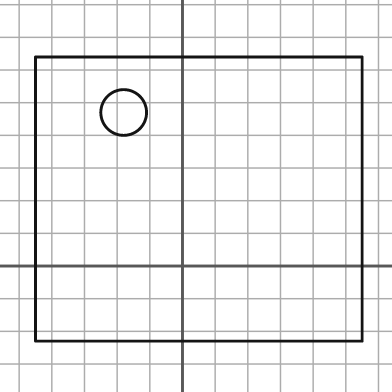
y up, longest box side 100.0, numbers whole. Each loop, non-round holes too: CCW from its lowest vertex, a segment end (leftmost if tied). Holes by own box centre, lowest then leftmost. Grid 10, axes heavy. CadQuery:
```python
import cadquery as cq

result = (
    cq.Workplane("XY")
    .moveTo(-45.0, -23.0)
    .lineTo(55.0, -23.0)
    .lineTo(55.0, 64.0)
    .lineTo(-45.0, 64.0)
    .close()
    .moveTo(-18.0, 47.0)
    .circle(7.0)
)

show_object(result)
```